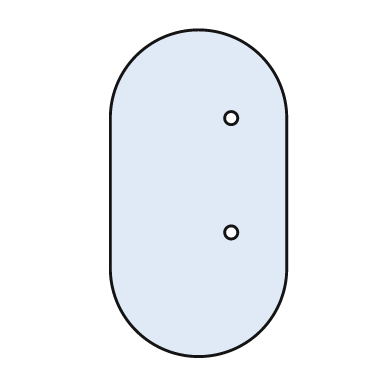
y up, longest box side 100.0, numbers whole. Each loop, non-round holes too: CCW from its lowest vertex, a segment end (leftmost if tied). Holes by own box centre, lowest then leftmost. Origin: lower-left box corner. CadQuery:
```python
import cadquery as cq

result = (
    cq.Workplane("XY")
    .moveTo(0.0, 27.0)
    .threePointArc((27.0, 0.0), (54.0, 27.0))
    .lineTo(54.0, 73.0)
    .threePointArc((27.0, 100.0), (0.0, 73.0))
    .close()
    .moveTo(37.0, 38.0)
    .circle(2.0)
    .moveTo(37.0, 73.0)
    .circle(2.0)
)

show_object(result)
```